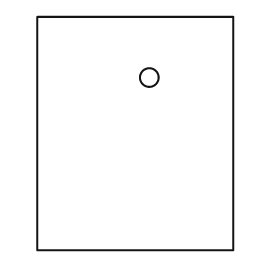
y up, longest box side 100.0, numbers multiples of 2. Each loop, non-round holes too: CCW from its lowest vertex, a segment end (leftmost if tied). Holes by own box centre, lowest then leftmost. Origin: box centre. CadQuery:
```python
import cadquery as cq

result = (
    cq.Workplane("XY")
    .moveTo(-42.0, -50.0)
    .lineTo(42.0, -50.0)
    .lineTo(42.0, 50.0)
    .lineTo(-42.0, 50.0)
    .close()
    .moveTo(6.0, 24.0)
    .circle(4.0)
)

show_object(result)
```